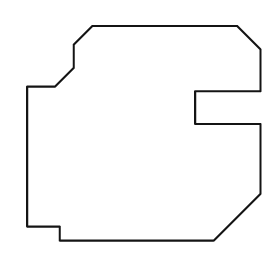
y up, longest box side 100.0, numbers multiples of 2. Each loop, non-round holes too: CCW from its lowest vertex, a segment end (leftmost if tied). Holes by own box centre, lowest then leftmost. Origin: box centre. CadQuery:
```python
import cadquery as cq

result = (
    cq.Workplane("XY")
    .moveTo(-36.0, -46.0)
    .lineTo(30.0, -46.0)
    .lineTo(50.0, -26.0)
    .lineTo(50.0, 4.0)
    .lineTo(22.0, 4.0)
    .lineTo(22.0, 18.0)
    .lineTo(50.0, 18.0)
    .lineTo(50.0, 36.0)
    .lineTo(40.0, 46.0)
    .lineTo(-22.0, 46.0)
    .lineTo(-30.0, 38.0)
    .lineTo(-30.0, 28.0)
    .lineTo(-38.0, 20.0)
    .lineTo(-50.0, 20.0)
    .lineTo(-50.0, -40.0)
    .lineTo(-36.0, -40.0)
    .close()
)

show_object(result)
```